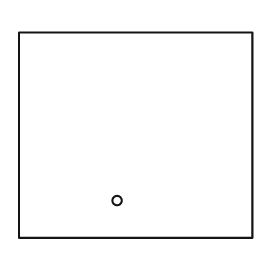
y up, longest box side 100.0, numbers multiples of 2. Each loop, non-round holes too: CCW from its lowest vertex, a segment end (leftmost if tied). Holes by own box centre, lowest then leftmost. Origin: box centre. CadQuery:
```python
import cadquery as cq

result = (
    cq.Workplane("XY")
    .moveTo(-50.0, -44.0)
    .lineTo(50.0, -44.0)
    .lineTo(50.0, 44.0)
    .lineTo(-50.0, 44.0)
    .close()
    .moveTo(-8.0, -28.0)
    .circle(2.0)
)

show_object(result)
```